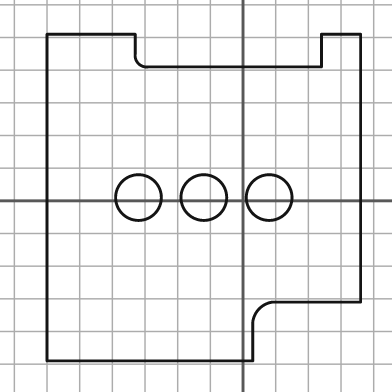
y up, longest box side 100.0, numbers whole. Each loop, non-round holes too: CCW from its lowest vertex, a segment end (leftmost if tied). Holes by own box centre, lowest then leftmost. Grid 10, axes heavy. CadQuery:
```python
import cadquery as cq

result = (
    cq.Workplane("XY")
    .moveTo(-60.0, -49.0)
    .lineTo(3.0, -49.0)
    .lineTo(3.0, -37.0)
    .threePointArc((5.0, -33.0), (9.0, -31.0))
    .lineTo(36.0, -31.0)
    .lineTo(36.0, 51.0)
    .lineTo(24.0, 51.0)
    .lineTo(24.0, 41.0)
    .lineTo(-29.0, 41.0)
    .threePointArc((-32.0, 42.0), (-33.0, 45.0))
    .lineTo(-33.0, 51.0)
    .lineTo(-60.0, 51.0)
    .close()
    .moveTo(-32.0, 1.0)
    .circle(7.0)
    .moveTo(-12.0, 1.0)
    .circle(7.0)
    .moveTo(8.0, 1.0)
    .circle(7.0)
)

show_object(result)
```